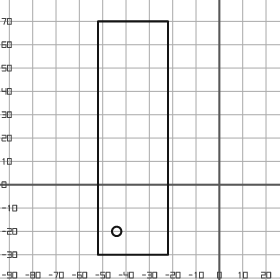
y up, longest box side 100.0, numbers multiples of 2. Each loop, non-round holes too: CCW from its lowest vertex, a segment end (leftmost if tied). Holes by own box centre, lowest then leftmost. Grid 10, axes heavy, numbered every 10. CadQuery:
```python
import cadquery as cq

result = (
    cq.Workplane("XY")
    .moveTo(-52.0, -30.0)
    .lineTo(-22.0, -30.0)
    .lineTo(-22.0, 70.0)
    .lineTo(-52.0, 70.0)
    .close()
    .moveTo(-44.0, -20.0)
    .circle(2.0)
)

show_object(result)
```